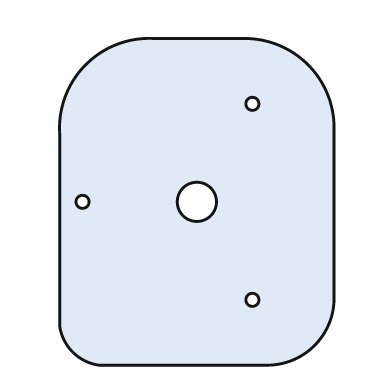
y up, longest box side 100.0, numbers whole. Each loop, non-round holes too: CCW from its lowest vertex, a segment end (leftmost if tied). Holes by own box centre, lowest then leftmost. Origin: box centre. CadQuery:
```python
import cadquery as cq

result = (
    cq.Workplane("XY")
    .moveTo(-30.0, -50.0)
    .lineTo(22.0, -50.0)
    .threePointArc((36.0, -44.0), (42.0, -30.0))
    .lineTo(42.0, 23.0)
    .threePointArc((34.0, 42.0), (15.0, 50.0))
    .lineTo(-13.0, 50.0)
    .threePointArc((-34.0, 42.0), (-42.0, 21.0))
    .lineTo(-42.0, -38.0)
    .threePointArc((-38.0, -46.0), (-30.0, -50.0))
    .close()
    .moveTo(17.0, -30.0)
    .circle(2.0)
    .moveTo(-35.0, 0.0)
    .circle(2.0)
    .moveTo(0.0, 0.0)
    .circle(6.0)
    .moveTo(17.0, 30.0)
    .circle(2.0)
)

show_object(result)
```